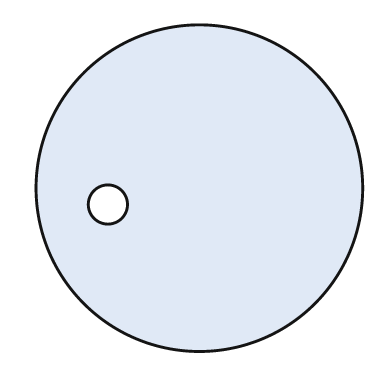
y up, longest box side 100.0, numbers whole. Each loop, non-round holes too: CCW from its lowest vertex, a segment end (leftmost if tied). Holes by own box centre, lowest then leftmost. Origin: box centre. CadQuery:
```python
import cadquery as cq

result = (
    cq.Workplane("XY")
    .moveTo(0.0, 0.0)
    .circle(50.0)
    .moveTo(-28.0, -5.0)
    .circle(6.0)
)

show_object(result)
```